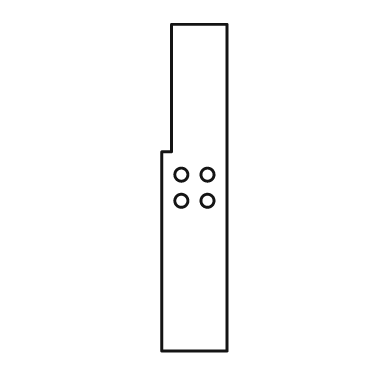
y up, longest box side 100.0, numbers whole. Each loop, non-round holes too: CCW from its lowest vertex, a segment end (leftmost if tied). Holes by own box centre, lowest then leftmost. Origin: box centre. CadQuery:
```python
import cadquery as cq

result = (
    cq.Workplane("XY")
    .moveTo(-10.0, -50.0)
    .lineTo(10.0, -50.0)
    .lineTo(10.0, 50.0)
    .lineTo(-7.0, 50.0)
    .lineTo(-7.0, 11.0)
    .lineTo(-10.0, 11.0)
    .close()
    .moveTo(-4.0, -4.0)
    .circle(2.0)
    .moveTo(4.0, -4.0)
    .circle(2.0)
    .moveTo(-4.0, 4.0)
    .circle(2.0)
    .moveTo(4.0, 4.0)
    .circle(2.0)
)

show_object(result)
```